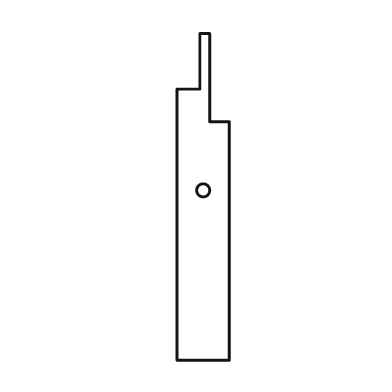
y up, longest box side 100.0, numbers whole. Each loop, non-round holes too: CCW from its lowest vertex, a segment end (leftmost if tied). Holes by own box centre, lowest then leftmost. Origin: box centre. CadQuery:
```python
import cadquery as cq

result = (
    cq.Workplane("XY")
    .moveTo(-8.0, -50.0)
    .lineTo(8.0, -50.0)
    .lineTo(8.0, 23.0)
    .lineTo(2.0, 23.0)
    .lineTo(2.0, 50.0)
    .lineTo(-1.0, 50.0)
    .lineTo(-1.0, 33.0)
    .lineTo(-8.0, 33.0)
    .close()
    .moveTo(0.0, 2.0)
    .circle(2.0)
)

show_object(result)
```